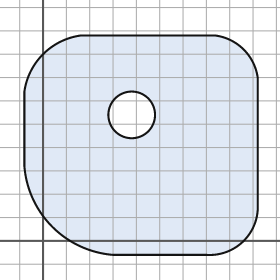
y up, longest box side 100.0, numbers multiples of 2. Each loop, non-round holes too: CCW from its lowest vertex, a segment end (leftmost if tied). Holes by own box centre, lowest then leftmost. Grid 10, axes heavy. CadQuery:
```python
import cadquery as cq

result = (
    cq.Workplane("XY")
    .moveTo(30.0, -6.0)
    .lineTo(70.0, -6.0)
    .threePointArc((86.0, 0.0), (92.0, 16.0))
    .lineTo(92.0, 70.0)
    .threePointArc((86.0, 82.0), (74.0, 88.0))
    .lineTo(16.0, 88.0)
    .threePointArc((0.0, 80.0), (-8.0, 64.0))
    .lineTo(-8.0, 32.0)
    .threePointArc((4.0, 6.0), (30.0, -6.0))
    .close()
    .moveTo(38.0, 54.0)
    .circle(10.0)
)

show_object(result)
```